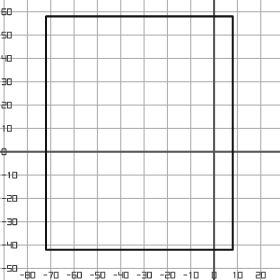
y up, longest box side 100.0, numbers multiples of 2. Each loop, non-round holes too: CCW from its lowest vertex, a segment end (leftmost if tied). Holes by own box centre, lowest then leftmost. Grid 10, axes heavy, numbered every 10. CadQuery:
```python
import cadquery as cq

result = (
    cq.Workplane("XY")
    .moveTo(-72.0, -42.0)
    .lineTo(8.0, -42.0)
    .lineTo(8.0, 58.0)
    .lineTo(-72.0, 58.0)
    .close()
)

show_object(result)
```